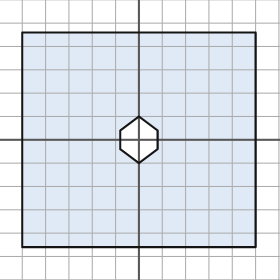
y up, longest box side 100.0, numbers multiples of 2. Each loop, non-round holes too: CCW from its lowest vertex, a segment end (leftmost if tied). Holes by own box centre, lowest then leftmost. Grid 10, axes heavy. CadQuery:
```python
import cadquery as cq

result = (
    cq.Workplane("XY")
    .moveTo(-50.0, -46.0)
    .lineTo(50.0, -46.0)
    .lineTo(50.0, 46.0)
    .lineTo(-50.0, 46.0)
    .close()
    .moveTo(0.0, -10.0)
    .lineTo(8.0, -4.0)
    .lineTo(8.0, 4.0)
    .lineTo(0.0, 10.0)
    .lineTo(-8.0, 4.0)
    .lineTo(-8.0, -4.0)
    .close()
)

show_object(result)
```